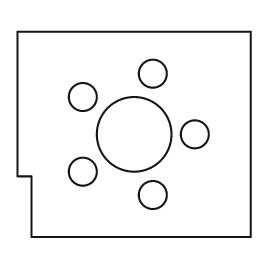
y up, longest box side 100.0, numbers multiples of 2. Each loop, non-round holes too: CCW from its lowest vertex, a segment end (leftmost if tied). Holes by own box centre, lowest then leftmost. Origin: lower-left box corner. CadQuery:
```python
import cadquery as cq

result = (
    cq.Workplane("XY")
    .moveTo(6.0, 0.0)
    .lineTo(100.0, 0.0)
    .lineTo(100.0, 88.0)
    .lineTo(0.0, 88.0)
    .lineTo(0.0, 26.0)
    .lineTo(6.0, 26.0)
    .close()
    .moveTo(58.0, 18.0)
    .circle(6.0)
    .moveTo(28.0, 28.0)
    .circle(6.0)
    .moveTo(50.0, 44.0)
    .circle(16.0)
    .moveTo(76.0, 44.0)
    .circle(6.0)
    .moveTo(28.0, 60.0)
    .circle(6.0)
    .moveTo(58.0, 70.0)
    .circle(6.0)
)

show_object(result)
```